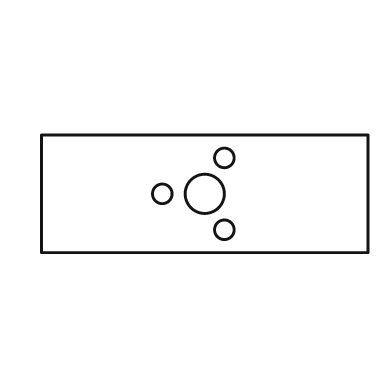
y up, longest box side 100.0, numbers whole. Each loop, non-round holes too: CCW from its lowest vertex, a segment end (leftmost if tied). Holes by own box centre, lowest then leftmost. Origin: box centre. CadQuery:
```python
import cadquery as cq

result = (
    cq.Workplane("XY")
    .moveTo(-50.0, -18.0)
    .lineTo(50.0, -18.0)
    .lineTo(50.0, 18.0)
    .lineTo(-50.0, 18.0)
    .close()
    .moveTo(6.0, -11.0)
    .circle(3.0)
    .moveTo(-13.0, 0.0)
    .circle(3.0)
    .moveTo(0.0, 0.0)
    .circle(6.0)
    .moveTo(6.0, 11.0)
    .circle(3.0)
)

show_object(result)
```